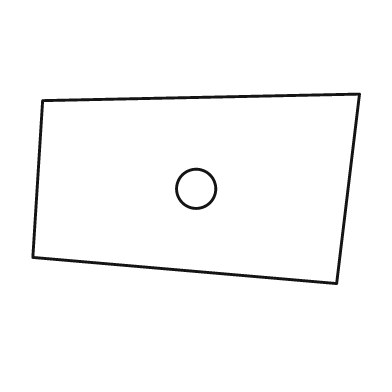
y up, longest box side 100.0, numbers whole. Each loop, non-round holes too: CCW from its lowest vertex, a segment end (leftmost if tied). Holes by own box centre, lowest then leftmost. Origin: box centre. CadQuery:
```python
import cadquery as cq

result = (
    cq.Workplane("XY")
    .moveTo(43.0, -29.0)
    .lineTo(50.0, 29.0)
    .lineTo(-47.0, 27.0)
    .lineTo(-50.0, -21.0)
    .close()
    .moveTo(0.0, 0.0)
    .circle(6.0)
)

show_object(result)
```